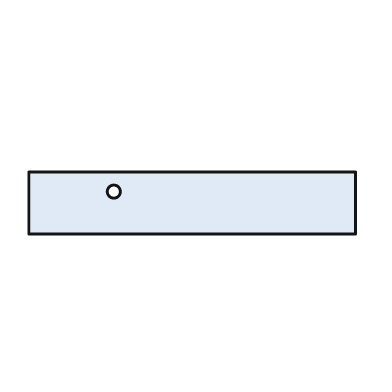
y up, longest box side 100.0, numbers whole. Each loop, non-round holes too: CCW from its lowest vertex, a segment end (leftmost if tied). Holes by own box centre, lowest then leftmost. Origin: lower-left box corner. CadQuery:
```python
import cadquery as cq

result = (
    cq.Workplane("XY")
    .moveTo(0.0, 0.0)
    .lineTo(100.0, 0.0)
    .lineTo(100.0, 19.0)
    .lineTo(0.0, 19.0)
    .close()
    .moveTo(26.0, 13.0)
    .circle(2.0)
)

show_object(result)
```